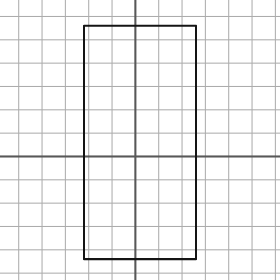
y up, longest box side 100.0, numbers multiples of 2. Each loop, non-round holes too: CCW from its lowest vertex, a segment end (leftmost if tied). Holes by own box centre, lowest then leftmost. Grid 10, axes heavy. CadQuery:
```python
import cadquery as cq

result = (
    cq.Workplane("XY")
    .moveTo(-22.0, -44.0)
    .lineTo(26.0, -44.0)
    .lineTo(26.0, 56.0)
    .lineTo(-22.0, 56.0)
    .close()
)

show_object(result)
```